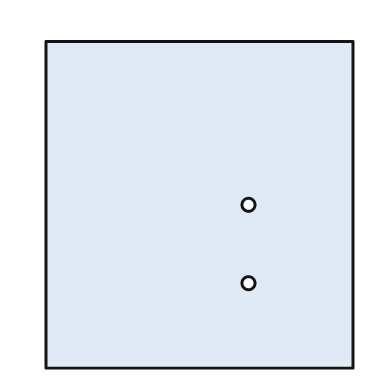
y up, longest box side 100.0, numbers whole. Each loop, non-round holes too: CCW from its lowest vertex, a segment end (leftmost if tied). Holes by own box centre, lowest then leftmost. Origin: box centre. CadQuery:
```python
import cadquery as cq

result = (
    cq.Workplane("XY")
    .moveTo(-47.0, -50.0)
    .lineTo(47.0, -50.0)
    .lineTo(47.0, 50.0)
    .lineTo(-47.0, 50.0)
    .close()
    .moveTo(15.0, -24.0)
    .circle(2.0)
    .moveTo(15.0, 0.0)
    .circle(2.0)
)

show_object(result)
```